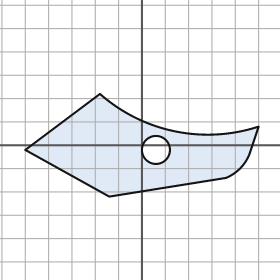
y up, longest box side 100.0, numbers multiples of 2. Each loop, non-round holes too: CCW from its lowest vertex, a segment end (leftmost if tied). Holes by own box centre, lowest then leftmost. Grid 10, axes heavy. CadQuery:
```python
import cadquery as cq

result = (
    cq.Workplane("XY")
    .moveTo(-14.0, -22.0)
    .lineTo(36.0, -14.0)
    .threePointArc((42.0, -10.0), (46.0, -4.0))
    .lineTo(50.0, 8.0)
    .threePointArc((14.0, 6.0), (-18.0, 22.0))
    .lineTo(-50.0, -2.0)
    .close()
    .moveTo(6.0, -2.0)
    .circle(6.0)
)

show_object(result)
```